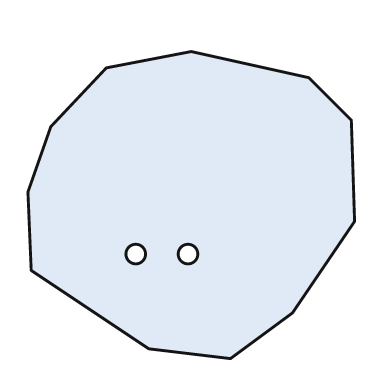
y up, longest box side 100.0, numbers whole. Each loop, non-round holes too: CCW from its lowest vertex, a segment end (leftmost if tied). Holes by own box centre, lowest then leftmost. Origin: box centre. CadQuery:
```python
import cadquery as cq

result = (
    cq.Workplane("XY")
    .moveTo(12.0, -47.0)
    .lineTo(31.0, -33.0)
    .lineTo(50.0, -5.0)
    .lineTo(49.0, 26.0)
    .lineTo(36.0, 39.0)
    .lineTo(0.0, 47.0)
    .lineTo(-26.0, 42.0)
    .lineTo(-43.0, 24.0)
    .lineTo(-50.0, 4.0)
    .lineTo(-49.0, -20.0)
    .lineTo(-13.0, -44.0)
    .close()
    .moveTo(-17.0, -15.0)
    .circle(3.0)
    .moveTo(-1.0, -15.0)
    .circle(3.0)
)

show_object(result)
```